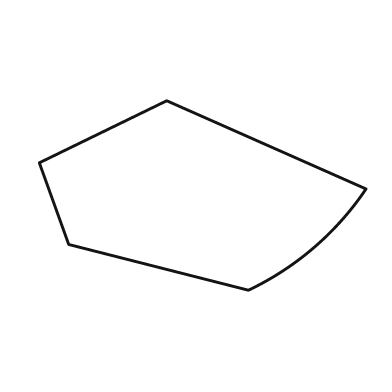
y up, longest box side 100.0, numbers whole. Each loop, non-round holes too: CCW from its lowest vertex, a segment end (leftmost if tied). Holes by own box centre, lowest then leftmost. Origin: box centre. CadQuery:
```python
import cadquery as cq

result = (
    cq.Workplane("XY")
    .moveTo(14.0, -29.0)
    .threePointArc((34.0, -16.0), (50.0, 2.0))
    .lineTo(-11.0, 29.0)
    .lineTo(-50.0, 10.0)
    .lineTo(-41.0, -15.0)
    .close()
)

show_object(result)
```